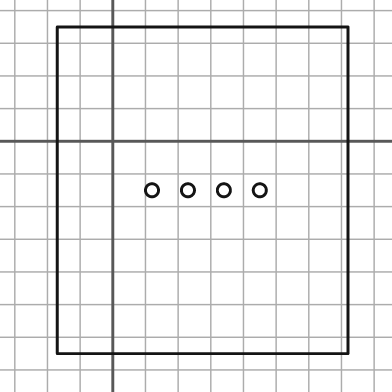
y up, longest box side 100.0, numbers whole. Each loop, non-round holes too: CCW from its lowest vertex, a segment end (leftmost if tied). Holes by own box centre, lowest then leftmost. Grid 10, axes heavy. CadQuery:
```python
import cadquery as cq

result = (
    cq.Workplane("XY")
    .moveTo(-17.0, -65.0)
    .lineTo(72.0, -65.0)
    .lineTo(72.0, 35.0)
    .lineTo(-17.0, 35.0)
    .close()
    .moveTo(12.0, -15.0)
    .circle(2.0)
    .moveTo(23.0, -15.0)
    .circle(2.0)
    .moveTo(34.0, -15.0)
    .circle(2.0)
    .moveTo(45.0, -15.0)
    .circle(2.0)
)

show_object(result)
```